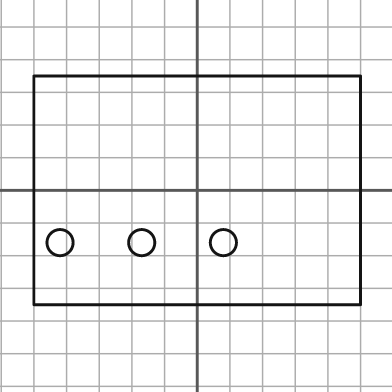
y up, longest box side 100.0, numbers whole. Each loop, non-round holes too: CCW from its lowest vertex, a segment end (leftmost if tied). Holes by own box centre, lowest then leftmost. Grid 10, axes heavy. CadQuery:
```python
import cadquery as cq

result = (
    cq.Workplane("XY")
    .moveTo(-50.0, -35.0)
    .lineTo(50.0, -35.0)
    .lineTo(50.0, 35.0)
    .lineTo(-50.0, 35.0)
    .close()
    .moveTo(-42.0, -16.0)
    .circle(4.0)
    .moveTo(-17.0, -16.0)
    .circle(4.0)
    .moveTo(8.0, -16.0)
    .circle(4.0)
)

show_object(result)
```